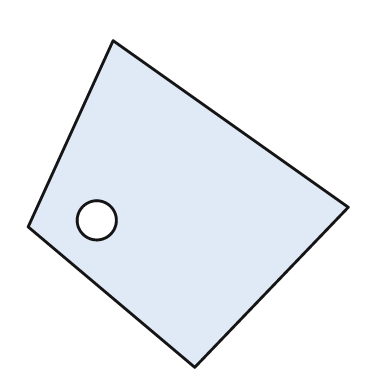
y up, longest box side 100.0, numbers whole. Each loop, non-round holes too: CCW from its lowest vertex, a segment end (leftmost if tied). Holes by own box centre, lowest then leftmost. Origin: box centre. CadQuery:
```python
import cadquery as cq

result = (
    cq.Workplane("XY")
    .moveTo(2.0, -50.0)
    .lineTo(49.0, -1.0)
    .lineTo(-23.0, 50.0)
    .lineTo(-49.0, -7.0)
    .close()
    .moveTo(-28.0, -5.0)
    .circle(6.0)
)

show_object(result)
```